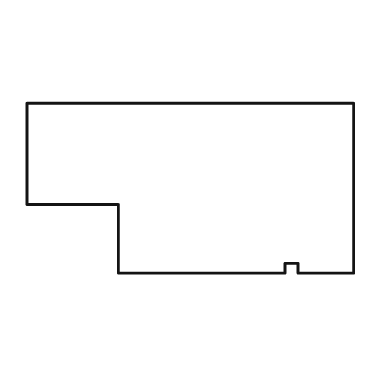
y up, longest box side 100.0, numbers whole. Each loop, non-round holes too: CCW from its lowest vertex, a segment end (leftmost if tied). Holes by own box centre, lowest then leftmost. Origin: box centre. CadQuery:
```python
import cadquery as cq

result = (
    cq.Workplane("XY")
    .moveTo(-22.0, -26.0)
    .lineTo(29.0, -26.0)
    .lineTo(29.0, -23.0)
    .lineTo(33.0, -23.0)
    .lineTo(33.0, -26.0)
    .lineTo(50.0, -26.0)
    .lineTo(50.0, 26.0)
    .lineTo(-50.0, 26.0)
    .lineTo(-50.0, -5.0)
    .lineTo(-22.0, -5.0)
    .close()
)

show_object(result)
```